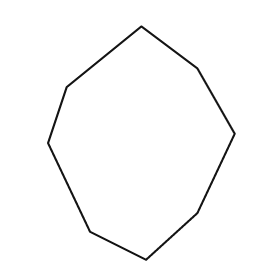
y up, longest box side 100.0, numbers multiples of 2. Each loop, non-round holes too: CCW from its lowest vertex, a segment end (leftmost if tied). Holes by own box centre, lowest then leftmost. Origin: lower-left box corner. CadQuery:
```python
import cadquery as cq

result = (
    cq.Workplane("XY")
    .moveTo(42.0, 0.0)
    .lineTo(64.0, 20.0)
    .lineTo(80.0, 54.0)
    .lineTo(64.0, 82.0)
    .lineTo(40.0, 100.0)
    .lineTo(8.0, 74.0)
    .lineTo(0.0, 50.0)
    .lineTo(18.0, 12.0)
    .close()
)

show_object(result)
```